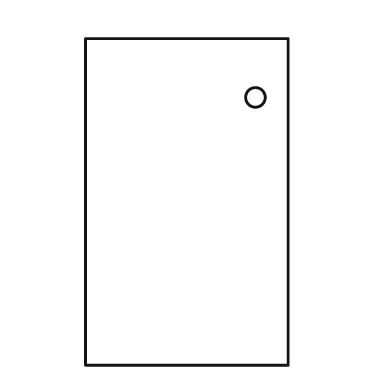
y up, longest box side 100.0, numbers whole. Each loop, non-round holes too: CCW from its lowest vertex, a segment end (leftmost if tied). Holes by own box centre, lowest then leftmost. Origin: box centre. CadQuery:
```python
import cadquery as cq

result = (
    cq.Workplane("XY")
    .moveTo(-31.0, -50.0)
    .lineTo(31.0, -50.0)
    .lineTo(31.0, 50.0)
    .lineTo(-31.0, 50.0)
    .close()
    .moveTo(21.0, 32.0)
    .circle(3.0)
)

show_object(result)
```